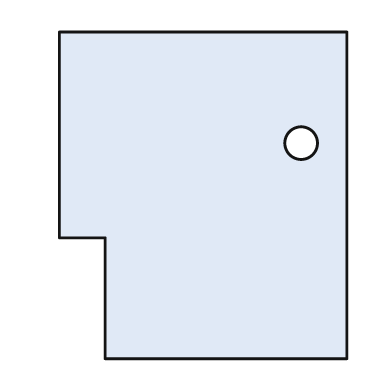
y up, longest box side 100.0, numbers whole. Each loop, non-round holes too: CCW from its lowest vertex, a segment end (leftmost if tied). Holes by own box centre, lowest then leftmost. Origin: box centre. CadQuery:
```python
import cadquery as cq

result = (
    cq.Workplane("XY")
    .moveTo(-30.0, -50.0)
    .lineTo(44.0, -50.0)
    .lineTo(44.0, 50.0)
    .lineTo(-44.0, 50.0)
    .lineTo(-44.0, -13.0)
    .lineTo(-30.0, -13.0)
    .close()
    .moveTo(30.0, 16.0)
    .circle(5.0)
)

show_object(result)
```